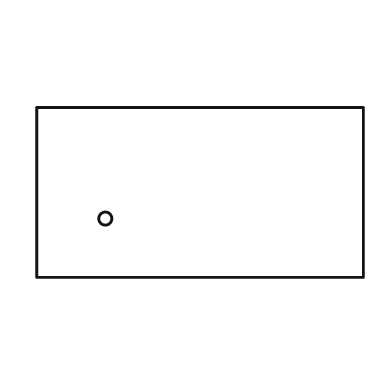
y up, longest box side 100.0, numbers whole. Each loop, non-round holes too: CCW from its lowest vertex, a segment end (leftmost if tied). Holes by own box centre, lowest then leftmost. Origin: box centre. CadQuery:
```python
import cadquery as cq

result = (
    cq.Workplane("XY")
    .moveTo(-50.0, -26.0)
    .lineTo(50.0, -26.0)
    .lineTo(50.0, 26.0)
    .lineTo(-50.0, 26.0)
    .close()
    .moveTo(-29.0, -8.0)
    .circle(2.0)
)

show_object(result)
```